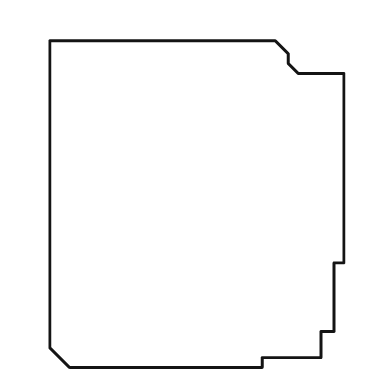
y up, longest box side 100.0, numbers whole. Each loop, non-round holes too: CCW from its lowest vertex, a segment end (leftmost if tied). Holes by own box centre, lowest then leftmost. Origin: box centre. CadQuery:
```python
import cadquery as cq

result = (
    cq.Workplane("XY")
    .moveTo(-39.0, -50.0)
    .lineTo(20.0, -50.0)
    .lineTo(20.0, -47.0)
    .lineTo(38.0, -47.0)
    .lineTo(38.0, -39.0)
    .lineTo(42.0, -39.0)
    .lineTo(42.0, -18.0)
    .lineTo(45.0, -18.0)
    .lineTo(45.0, 40.0)
    .lineTo(31.0, 40.0)
    .lineTo(28.0, 43.0)
    .lineTo(28.0, 46.0)
    .lineTo(24.0, 50.0)
    .lineTo(-45.0, 50.0)
    .lineTo(-45.0, -44.0)
    .close()
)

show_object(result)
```